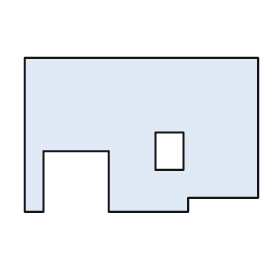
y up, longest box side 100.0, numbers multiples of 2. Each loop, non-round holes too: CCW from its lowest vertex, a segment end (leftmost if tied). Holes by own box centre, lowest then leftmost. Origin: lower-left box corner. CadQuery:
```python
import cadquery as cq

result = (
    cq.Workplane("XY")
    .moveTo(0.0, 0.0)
    .lineTo(8.0, 0.0)
    .lineTo(8.0, 26.0)
    .lineTo(36.0, 26.0)
    .lineTo(36.0, 0.0)
    .lineTo(70.0, 0.0)
    .lineTo(70.0, 6.0)
    .lineTo(100.0, 6.0)
    .lineTo(100.0, 66.0)
    .lineTo(0.0, 66.0)
    .close()
    .moveTo(56.0, 18.0)
    .lineTo(68.0, 18.0)
    .lineTo(68.0, 34.0)
    .lineTo(56.0, 34.0)
    .close()
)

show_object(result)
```